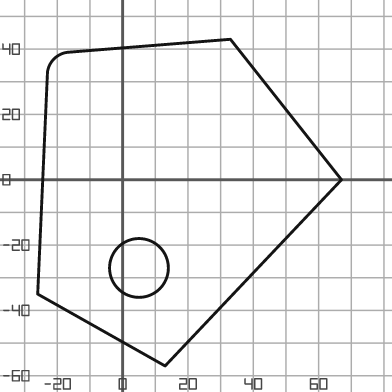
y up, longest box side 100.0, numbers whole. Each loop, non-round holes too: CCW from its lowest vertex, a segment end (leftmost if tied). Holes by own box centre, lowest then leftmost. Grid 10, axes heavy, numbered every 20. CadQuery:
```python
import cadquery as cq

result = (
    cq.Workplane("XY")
    .moveTo(13.0, -57.0)
    .lineTo(67.0, 0.0)
    .lineTo(33.0, 43.0)
    .lineTo(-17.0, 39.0)
    .threePointArc((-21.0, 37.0), (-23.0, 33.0))
    .lineTo(-26.0, -35.0)
    .close()
    .moveTo(5.0, -27.0)
    .circle(9.0)
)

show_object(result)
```